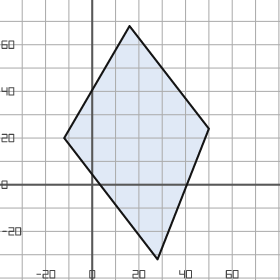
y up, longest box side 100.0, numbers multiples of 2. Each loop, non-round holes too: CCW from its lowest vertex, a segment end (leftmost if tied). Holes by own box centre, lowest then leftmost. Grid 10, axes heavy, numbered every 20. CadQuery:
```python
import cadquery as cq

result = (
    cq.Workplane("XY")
    .moveTo(28.0, -32.0)
    .lineTo(50.0, 24.0)
    .lineTo(16.0, 68.0)
    .lineTo(-12.0, 20.0)
    .close()
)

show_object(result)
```